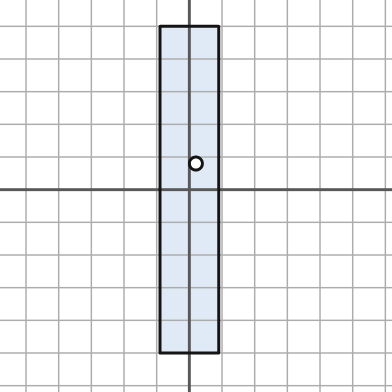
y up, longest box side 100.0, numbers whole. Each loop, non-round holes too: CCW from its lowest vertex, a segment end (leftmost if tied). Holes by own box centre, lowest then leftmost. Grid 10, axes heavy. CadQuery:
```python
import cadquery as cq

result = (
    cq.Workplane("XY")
    .moveTo(-9.0, -50.0)
    .lineTo(9.0, -50.0)
    .lineTo(9.0, 50.0)
    .lineTo(-9.0, 50.0)
    .close()
    .moveTo(2.0, 8.0)
    .circle(2.0)
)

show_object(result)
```